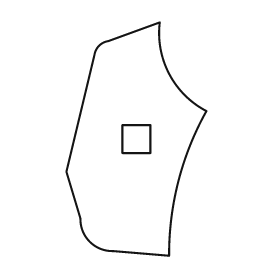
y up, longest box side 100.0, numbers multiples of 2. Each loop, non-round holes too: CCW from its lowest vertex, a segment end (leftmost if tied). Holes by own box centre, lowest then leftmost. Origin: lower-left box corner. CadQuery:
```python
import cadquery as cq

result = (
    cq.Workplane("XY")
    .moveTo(44.0, 0.0)
    .threePointArc((48.0, 32.0), (60.0, 62.0))
    .threePointArc((44.0, 78.0), (40.0, 100.0))
    .lineTo(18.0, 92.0)
    .threePointArc((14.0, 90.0), (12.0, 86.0))
    .lineTo(0.0, 36.0)
    .lineTo(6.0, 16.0)
    .threePointArc((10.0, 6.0), (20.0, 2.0))
    .close()
    .moveTo(24.0, 44.0)
    .lineTo(36.0, 44.0)
    .lineTo(36.0, 56.0)
    .lineTo(24.0, 56.0)
    .close()
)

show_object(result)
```